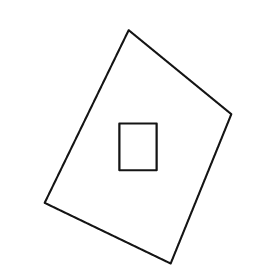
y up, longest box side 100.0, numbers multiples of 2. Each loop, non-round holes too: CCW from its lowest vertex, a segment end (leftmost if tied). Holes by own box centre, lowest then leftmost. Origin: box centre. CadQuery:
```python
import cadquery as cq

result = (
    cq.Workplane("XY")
    .moveTo(14.0, -50.0)
    .lineTo(40.0, 14.0)
    .lineTo(-4.0, 50.0)
    .lineTo(-40.0, -24.0)
    .close()
    .moveTo(-8.0, -10.0)
    .lineTo(8.0, -10.0)
    .lineTo(8.0, 10.0)
    .lineTo(-8.0, 10.0)
    .close()
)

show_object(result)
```